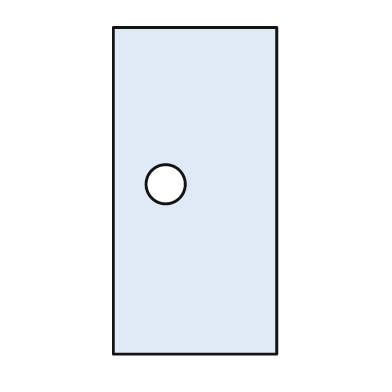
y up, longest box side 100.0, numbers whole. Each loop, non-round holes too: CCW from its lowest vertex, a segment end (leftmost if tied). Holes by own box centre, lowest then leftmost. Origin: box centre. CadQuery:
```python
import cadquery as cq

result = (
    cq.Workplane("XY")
    .moveTo(-25.0, -50.0)
    .lineTo(25.0, -50.0)
    .lineTo(25.0, 50.0)
    .lineTo(-25.0, 50.0)
    .close()
    .moveTo(-9.0, 2.0)
    .circle(6.0)
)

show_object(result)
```